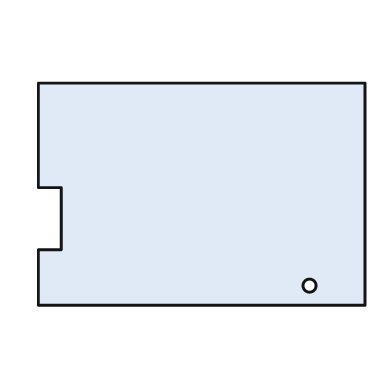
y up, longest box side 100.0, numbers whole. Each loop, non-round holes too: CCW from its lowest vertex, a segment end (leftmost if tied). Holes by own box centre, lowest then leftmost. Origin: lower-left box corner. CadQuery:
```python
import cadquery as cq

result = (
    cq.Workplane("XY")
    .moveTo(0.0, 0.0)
    .lineTo(100.0, 0.0)
    .lineTo(100.0, 68.0)
    .lineTo(0.0, 68.0)
    .lineTo(0.0, 36.0)
    .lineTo(7.0, 36.0)
    .lineTo(7.0, 17.0)
    .lineTo(0.0, 17.0)
    .close()
    .moveTo(83.0, 6.0)
    .circle(2.0)
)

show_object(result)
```